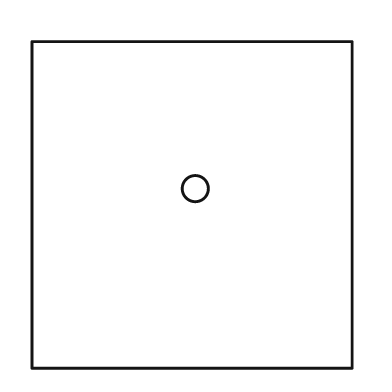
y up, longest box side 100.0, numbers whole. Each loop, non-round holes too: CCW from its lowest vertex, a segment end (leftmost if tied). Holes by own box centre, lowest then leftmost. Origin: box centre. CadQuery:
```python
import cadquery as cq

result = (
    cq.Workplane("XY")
    .moveTo(-49.0, -50.0)
    .lineTo(49.0, -50.0)
    .lineTo(49.0, 50.0)
    .lineTo(-49.0, 50.0)
    .close()
    .moveTo(1.0, 5.0)
    .circle(4.0)
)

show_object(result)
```